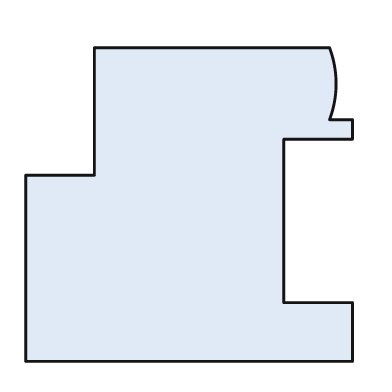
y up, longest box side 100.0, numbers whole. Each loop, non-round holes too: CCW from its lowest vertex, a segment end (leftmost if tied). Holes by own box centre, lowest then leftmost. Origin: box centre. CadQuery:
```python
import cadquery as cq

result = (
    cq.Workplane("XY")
    .moveTo(-50.0, -48.0)
    .lineTo(50.0, -48.0)
    .lineTo(50.0, -30.0)
    .lineTo(29.0, -30.0)
    .lineTo(29.0, 20.0)
    .lineTo(50.0, 20.0)
    .lineTo(50.0, 26.0)
    .lineTo(43.0, 26.0)
    .threePointArc((45.0, 37.0), (43.0, 48.0))
    .lineTo(-29.0, 48.0)
    .lineTo(-29.0, 9.0)
    .lineTo(-50.0, 9.0)
    .close()
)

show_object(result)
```